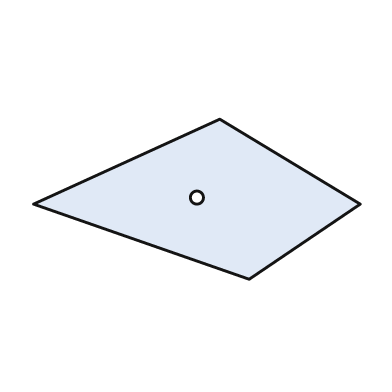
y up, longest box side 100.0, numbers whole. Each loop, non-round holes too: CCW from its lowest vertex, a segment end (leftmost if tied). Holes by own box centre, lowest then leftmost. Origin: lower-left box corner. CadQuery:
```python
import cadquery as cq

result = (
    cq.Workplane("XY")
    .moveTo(66.0, 0.0)
    .lineTo(100.0, 23.0)
    .lineTo(57.0, 49.0)
    .lineTo(0.0, 23.0)
    .close()
    .moveTo(50.0, 25.0)
    .circle(2.0)
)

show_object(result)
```